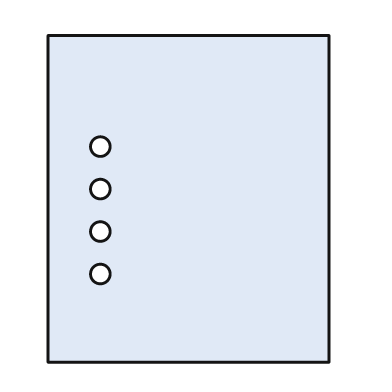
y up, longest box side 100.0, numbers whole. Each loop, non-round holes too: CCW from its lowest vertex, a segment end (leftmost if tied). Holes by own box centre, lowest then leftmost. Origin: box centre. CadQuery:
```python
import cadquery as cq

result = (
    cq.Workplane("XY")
    .moveTo(-43.0, -50.0)
    .lineTo(43.0, -50.0)
    .lineTo(43.0, 50.0)
    .lineTo(-43.0, 50.0)
    .close()
    .moveTo(-27.0, -23.0)
    .circle(3.0)
    .moveTo(-27.0, -10.0)
    .circle(3.0)
    .moveTo(-27.0, 3.0)
    .circle(3.0)
    .moveTo(-27.0, 16.0)
    .circle(3.0)
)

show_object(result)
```